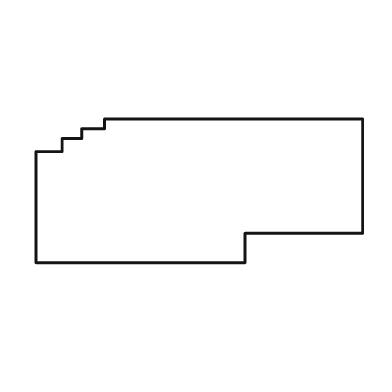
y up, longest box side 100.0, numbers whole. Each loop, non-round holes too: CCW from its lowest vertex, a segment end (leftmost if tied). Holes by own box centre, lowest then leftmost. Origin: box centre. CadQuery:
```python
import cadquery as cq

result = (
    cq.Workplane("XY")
    .moveTo(-50.0, -22.0)
    .lineTo(14.0, -22.0)
    .lineTo(14.0, -13.0)
    .lineTo(50.0, -13.0)
    .lineTo(50.0, 22.0)
    .lineTo(-29.0, 22.0)
    .lineTo(-29.0, 19.0)
    .lineTo(-36.0, 19.0)
    .lineTo(-36.0, 16.0)
    .lineTo(-42.0, 16.0)
    .lineTo(-42.0, 12.0)
    .lineTo(-50.0, 12.0)
    .close()
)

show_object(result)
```